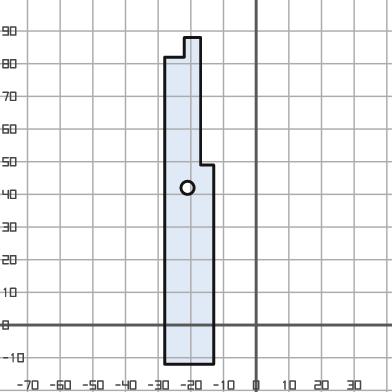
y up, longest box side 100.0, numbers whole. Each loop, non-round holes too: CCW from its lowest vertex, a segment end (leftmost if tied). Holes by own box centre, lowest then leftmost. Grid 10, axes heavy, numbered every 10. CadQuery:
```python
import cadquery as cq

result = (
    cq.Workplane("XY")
    .moveTo(-28.0, -12.0)
    .lineTo(-13.0, -12.0)
    .lineTo(-13.0, 49.0)
    .lineTo(-17.0, 49.0)
    .lineTo(-17.0, 88.0)
    .lineTo(-22.0, 88.0)
    .lineTo(-22.0, 82.0)
    .lineTo(-28.0, 82.0)
    .close()
    .moveTo(-21.0, 42.0)
    .circle(2.0)
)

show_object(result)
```